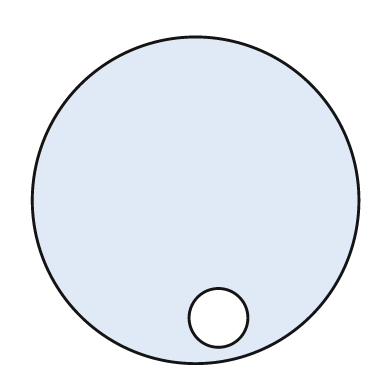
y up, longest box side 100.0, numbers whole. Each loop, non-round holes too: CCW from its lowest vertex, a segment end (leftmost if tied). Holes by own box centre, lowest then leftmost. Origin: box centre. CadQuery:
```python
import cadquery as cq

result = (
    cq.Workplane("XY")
    .moveTo(0.0, 0.0)
    .circle(50.0)
    .moveTo(7.0, -36.0)
    .circle(9.0)
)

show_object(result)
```